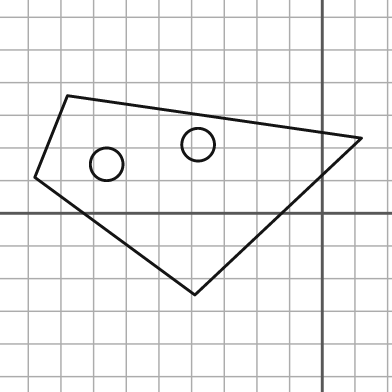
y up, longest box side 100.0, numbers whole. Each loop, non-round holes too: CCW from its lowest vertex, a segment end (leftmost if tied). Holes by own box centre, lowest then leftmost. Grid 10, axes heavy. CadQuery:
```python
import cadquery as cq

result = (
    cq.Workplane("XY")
    .moveTo(-39.0, -25.0)
    .lineTo(12.0, 23.0)
    .lineTo(-78.0, 36.0)
    .lineTo(-88.0, 11.0)
    .close()
    .moveTo(-66.0, 15.0)
    .circle(5.0)
    .moveTo(-38.0, 21.0)
    .circle(5.0)
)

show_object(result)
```